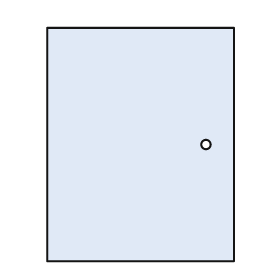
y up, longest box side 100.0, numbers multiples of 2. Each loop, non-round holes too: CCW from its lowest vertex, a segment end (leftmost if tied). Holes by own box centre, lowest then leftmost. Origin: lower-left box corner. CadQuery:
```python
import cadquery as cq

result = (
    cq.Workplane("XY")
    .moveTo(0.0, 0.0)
    .lineTo(80.0, 0.0)
    .lineTo(80.0, 100.0)
    .lineTo(0.0, 100.0)
    .close()
    .moveTo(68.0, 50.0)
    .circle(2.0)
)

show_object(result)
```